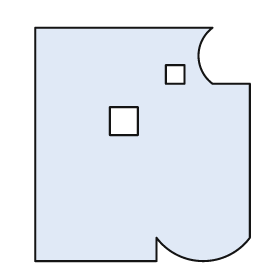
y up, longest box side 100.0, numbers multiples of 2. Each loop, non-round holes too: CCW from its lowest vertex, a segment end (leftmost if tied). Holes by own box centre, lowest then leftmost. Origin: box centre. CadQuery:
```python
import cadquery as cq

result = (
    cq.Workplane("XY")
    .moveTo(-46.0, -50.0)
    .lineTo(6.0, -50.0)
    .lineTo(6.0, -40.0)
    .threePointArc((26.0, -50.0), (46.0, -40.0))
    .lineTo(46.0, 26.0)
    .lineTo(30.0, 26.0)
    .threePointArc((24.0, 38.0), (30.0, 50.0))
    .lineTo(-46.0, 50.0)
    .close()
    .moveTo(-14.0, 4.0)
    .lineTo(-2.0, 4.0)
    .lineTo(-2.0, 16.0)
    .lineTo(-14.0, 16.0)
    .close()
    .moveTo(10.0, 26.0)
    .lineTo(18.0, 26.0)
    .lineTo(18.0, 34.0)
    .lineTo(10.0, 34.0)
    .close()
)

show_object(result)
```